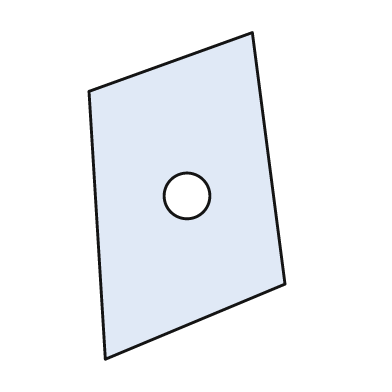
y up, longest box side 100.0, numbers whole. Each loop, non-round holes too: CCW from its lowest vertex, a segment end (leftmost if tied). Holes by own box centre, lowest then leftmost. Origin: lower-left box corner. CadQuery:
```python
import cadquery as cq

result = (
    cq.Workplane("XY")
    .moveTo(5.0, 0.0)
    .lineTo(60.0, 23.0)
    .lineTo(50.0, 100.0)
    .lineTo(0.0, 82.0)
    .close()
    .moveTo(30.0, 50.0)
    .circle(7.0)
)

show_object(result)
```